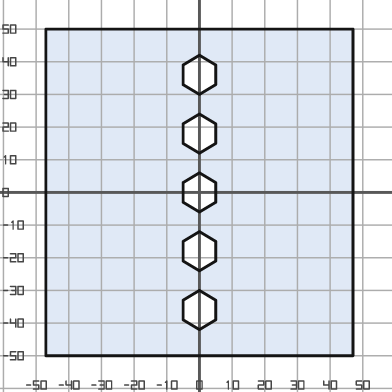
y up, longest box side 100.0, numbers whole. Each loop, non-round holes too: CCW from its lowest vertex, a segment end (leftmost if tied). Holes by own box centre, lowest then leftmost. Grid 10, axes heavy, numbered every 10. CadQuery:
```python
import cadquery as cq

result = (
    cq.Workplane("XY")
    .moveTo(-47.0, -50.0)
    .lineTo(47.0, -50.0)
    .lineTo(47.0, 50.0)
    .lineTo(-47.0, 50.0)
    .close()
    .moveTo(0.0, -42.0)
    .lineTo(5.0, -39.0)
    .lineTo(5.0, -33.0)
    .lineTo(0.0, -30.0)
    .lineTo(-5.0, -33.0)
    .lineTo(-5.0, -39.0)
    .close()
    .moveTo(0.0, -24.0)
    .lineTo(5.0, -21.0)
    .lineTo(5.0, -15.0)
    .lineTo(0.0, -12.0)
    .lineTo(-5.0, -15.0)
    .lineTo(-5.0, -21.0)
    .close()
    .moveTo(0.0, -6.0)
    .lineTo(5.0, -3.0)
    .lineTo(5.0, 3.0)
    .lineTo(0.0, 6.0)
    .lineTo(-5.0, 3.0)
    .lineTo(-5.0, -3.0)
    .close()
    .moveTo(0.0, 12.0)
    .lineTo(5.0, 15.0)
    .lineTo(5.0, 21.0)
    .lineTo(0.0, 24.0)
    .lineTo(-5.0, 21.0)
    .lineTo(-5.0, 15.0)
    .close()
    .moveTo(0.0, 30.0)
    .lineTo(5.0, 33.0)
    .lineTo(5.0, 39.0)
    .lineTo(0.0, 42.0)
    .lineTo(-5.0, 39.0)
    .lineTo(-5.0, 33.0)
    .close()
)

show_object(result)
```